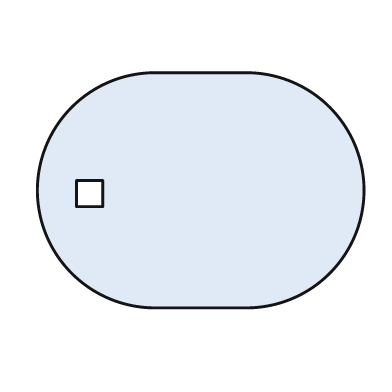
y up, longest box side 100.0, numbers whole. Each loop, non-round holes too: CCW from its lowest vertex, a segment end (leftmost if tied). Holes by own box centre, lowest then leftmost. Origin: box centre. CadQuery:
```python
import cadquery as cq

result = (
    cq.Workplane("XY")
    .moveTo(-14.0, -36.0)
    .lineTo(14.0, -36.0)
    .threePointArc((50.0, 0.0), (14.0, 36.0))
    .lineTo(-14.0, 36.0)
    .threePointArc((-50.0, 0.0), (-14.0, -36.0))
    .close()
    .moveTo(-38.0, -5.0)
    .lineTo(-30.0, -5.0)
    .lineTo(-30.0, 3.0)
    .lineTo(-38.0, 3.0)
    .close()
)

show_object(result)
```